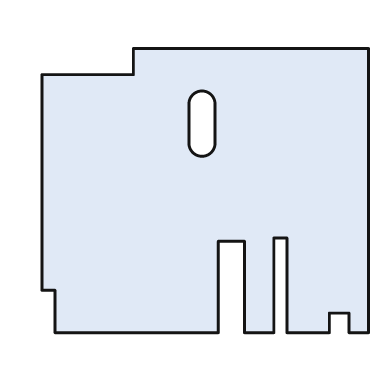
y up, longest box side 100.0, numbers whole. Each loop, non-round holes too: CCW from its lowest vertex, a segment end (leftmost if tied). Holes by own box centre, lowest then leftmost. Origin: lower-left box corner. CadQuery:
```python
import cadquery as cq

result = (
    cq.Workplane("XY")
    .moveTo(4.0, 0.0)
    .lineTo(54.0, 0.0)
    .lineTo(54.0, 28.0)
    .lineTo(62.0, 28.0)
    .lineTo(62.0, 0.0)
    .lineTo(71.0, 0.0)
    .lineTo(71.0, 29.0)
    .lineTo(75.0, 29.0)
    .lineTo(75.0, 0.0)
    .lineTo(88.0, 0.0)
    .lineTo(88.0, 6.0)
    .lineTo(94.0, 6.0)
    .lineTo(94.0, 0.0)
    .lineTo(100.0, 0.0)
    .lineTo(100.0, 87.0)
    .lineTo(28.0, 87.0)
    .lineTo(28.0, 79.0)
    .lineTo(0.0, 79.0)
    .lineTo(0.0, 13.0)
    .lineTo(4.0, 13.0)
    .close()
    .moveTo(45.0, 58.0)
    .threePointArc((49.0, 54.0), (53.0, 58.0))
    .lineTo(53.0, 70.0)
    .threePointArc((49.0, 74.0), (45.0, 70.0))
    .close()
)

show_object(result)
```